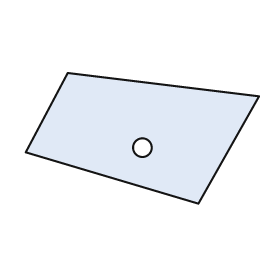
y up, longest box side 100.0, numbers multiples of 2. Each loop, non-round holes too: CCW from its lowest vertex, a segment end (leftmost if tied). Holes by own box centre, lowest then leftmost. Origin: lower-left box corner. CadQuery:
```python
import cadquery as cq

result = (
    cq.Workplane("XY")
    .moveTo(74.0, 0.0)
    .lineTo(100.0, 46.0)
    .lineTo(18.0, 56.0)
    .lineTo(0.0, 22.0)
    .close()
    .moveTo(50.0, 24.0)
    .circle(4.0)
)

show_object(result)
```